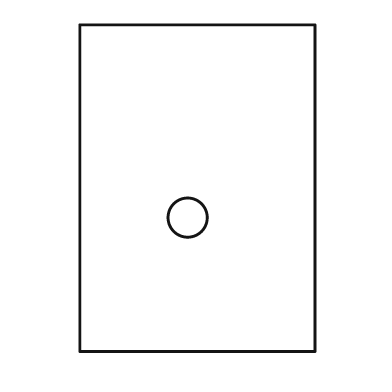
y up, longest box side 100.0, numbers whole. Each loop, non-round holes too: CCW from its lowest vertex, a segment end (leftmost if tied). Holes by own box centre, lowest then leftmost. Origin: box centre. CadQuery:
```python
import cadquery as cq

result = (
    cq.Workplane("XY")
    .moveTo(-36.0, -50.0)
    .lineTo(36.0, -50.0)
    .lineTo(36.0, 50.0)
    .lineTo(-36.0, 50.0)
    .close()
    .moveTo(-3.0, -9.0)
    .circle(6.0)
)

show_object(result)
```